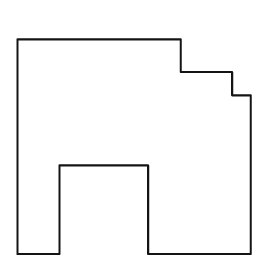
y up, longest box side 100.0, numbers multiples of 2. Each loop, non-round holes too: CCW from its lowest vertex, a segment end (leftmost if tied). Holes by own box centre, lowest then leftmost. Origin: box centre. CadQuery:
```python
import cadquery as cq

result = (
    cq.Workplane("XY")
    .moveTo(-50.0, -46.0)
    .lineTo(-32.0, -46.0)
    .lineTo(-32.0, -8.0)
    .lineTo(6.0, -8.0)
    .lineTo(6.0, -46.0)
    .lineTo(50.0, -46.0)
    .lineTo(50.0, 22.0)
    .lineTo(42.0, 22.0)
    .lineTo(42.0, 32.0)
    .lineTo(20.0, 32.0)
    .lineTo(20.0, 46.0)
    .lineTo(-50.0, 46.0)
    .close()
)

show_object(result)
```